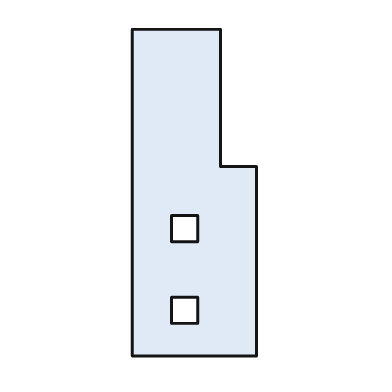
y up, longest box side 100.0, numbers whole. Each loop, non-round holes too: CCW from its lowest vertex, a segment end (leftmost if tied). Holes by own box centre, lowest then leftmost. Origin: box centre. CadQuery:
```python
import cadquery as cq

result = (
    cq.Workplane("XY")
    .moveTo(-19.0, -50.0)
    .lineTo(19.0, -50.0)
    .lineTo(19.0, 8.0)
    .lineTo(8.0, 8.0)
    .lineTo(8.0, 50.0)
    .lineTo(-19.0, 50.0)
    .close()
    .moveTo(-7.0, -40.0)
    .lineTo(1.0, -40.0)
    .lineTo(1.0, -32.0)
    .lineTo(-7.0, -32.0)
    .close()
    .moveTo(-7.0, -15.0)
    .lineTo(1.0, -15.0)
    .lineTo(1.0, -7.0)
    .lineTo(-7.0, -7.0)
    .close()
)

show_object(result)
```